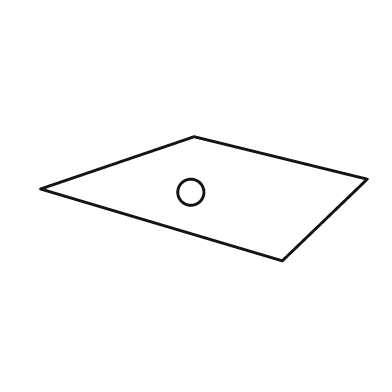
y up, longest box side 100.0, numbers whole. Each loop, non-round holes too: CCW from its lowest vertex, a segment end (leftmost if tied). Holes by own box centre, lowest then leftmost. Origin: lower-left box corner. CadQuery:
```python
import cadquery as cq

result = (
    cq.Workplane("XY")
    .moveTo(74.0, 0.0)
    .lineTo(100.0, 25.0)
    .lineTo(47.0, 38.0)
    .lineTo(0.0, 22.0)
    .close()
    .moveTo(46.0, 21.0)
    .circle(4.0)
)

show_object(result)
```